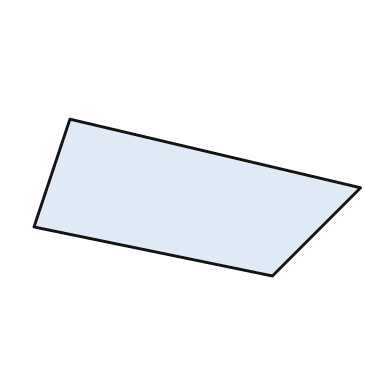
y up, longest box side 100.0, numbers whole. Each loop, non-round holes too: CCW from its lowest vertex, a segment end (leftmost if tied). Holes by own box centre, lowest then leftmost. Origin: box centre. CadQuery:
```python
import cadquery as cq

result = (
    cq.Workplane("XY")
    .moveTo(23.0, -24.0)
    .lineTo(50.0, 3.0)
    .lineTo(-39.0, 24.0)
    .lineTo(-50.0, -9.0)
    .close()
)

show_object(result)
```